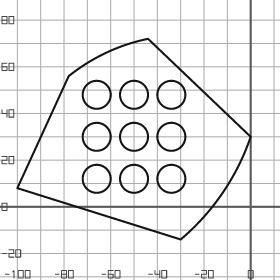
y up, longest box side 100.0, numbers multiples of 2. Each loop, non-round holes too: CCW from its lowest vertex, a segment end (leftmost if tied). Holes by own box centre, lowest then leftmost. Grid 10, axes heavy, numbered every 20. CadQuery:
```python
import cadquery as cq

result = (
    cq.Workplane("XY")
    .moveTo(-30.0, -14.0)
    .threePointArc((-12.0, 6.0), (0.0, 30.0))
    .lineTo(-44.0, 72.0)
    .threePointArc((-62.0, 66.0), (-78.0, 56.0))
    .lineTo(-100.0, 8.0)
    .close()
    .moveTo(-66.0, 12.0)
    .circle(6.0)
    .moveTo(-50.0, 12.0)
    .circle(6.0)
    .moveTo(-34.0, 12.0)
    .circle(6.0)
    .moveTo(-66.0, 30.0)
    .circle(6.0)
    .moveTo(-50.0, 30.0)
    .circle(6.0)
    .moveTo(-34.0, 30.0)
    .circle(6.0)
    .moveTo(-66.0, 48.0)
    .circle(6.0)
    .moveTo(-50.0, 48.0)
    .circle(6.0)
    .moveTo(-34.0, 48.0)
    .circle(6.0)
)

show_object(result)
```